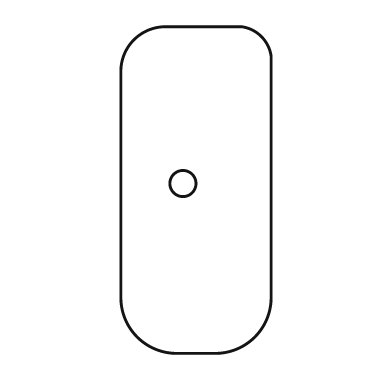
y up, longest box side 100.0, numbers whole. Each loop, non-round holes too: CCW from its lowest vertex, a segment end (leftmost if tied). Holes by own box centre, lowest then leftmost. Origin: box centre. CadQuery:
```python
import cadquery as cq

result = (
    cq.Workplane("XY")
    .moveTo(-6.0, -50.0)
    .lineTo(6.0, -50.0)
    .threePointArc((18.0, -45.0), (23.0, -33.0))
    .lineTo(23.0, 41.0)
    .threePointArc((20.0, 47.0), (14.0, 50.0))
    .lineTo(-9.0, 50.0)
    .threePointArc((-19.0, 46.0), (-23.0, 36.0))
    .lineTo(-23.0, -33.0)
    .threePointArc((-18.0, -45.0), (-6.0, -50.0))
    .close()
    .moveTo(-4.0, 2.0)
    .circle(4.0)
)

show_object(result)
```